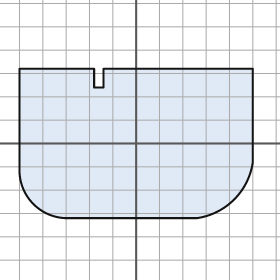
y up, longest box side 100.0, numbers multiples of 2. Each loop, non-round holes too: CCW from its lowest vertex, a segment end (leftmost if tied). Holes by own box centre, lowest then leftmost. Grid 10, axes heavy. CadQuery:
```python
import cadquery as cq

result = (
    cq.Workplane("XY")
    .moveTo(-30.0, -32.0)
    .lineTo(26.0, -32.0)
    .threePointArc((42.0, -24.0), (50.0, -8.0))
    .lineTo(50.0, 32.0)
    .lineTo(-14.0, 32.0)
    .lineTo(-14.0, 24.0)
    .lineTo(-18.0, 24.0)
    .lineTo(-18.0, 32.0)
    .lineTo(-50.0, 32.0)
    .lineTo(-50.0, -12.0)
    .threePointArc((-44.0, -26.0), (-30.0, -32.0))
    .close()
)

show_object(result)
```